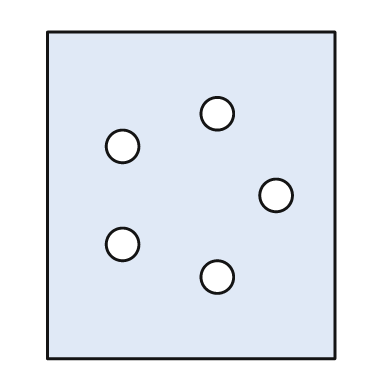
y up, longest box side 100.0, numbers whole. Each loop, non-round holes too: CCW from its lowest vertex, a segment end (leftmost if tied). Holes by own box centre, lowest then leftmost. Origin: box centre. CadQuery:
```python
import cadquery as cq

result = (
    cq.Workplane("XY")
    .moveTo(-44.0, -50.0)
    .lineTo(44.0, -50.0)
    .lineTo(44.0, 50.0)
    .lineTo(-44.0, 50.0)
    .close()
    .moveTo(8.0, -25.0)
    .circle(5.0)
    .moveTo(-21.0, -15.0)
    .circle(5.0)
    .moveTo(26.0, 0.0)
    .circle(5.0)
    .moveTo(-21.0, 15.0)
    .circle(5.0)
    .moveTo(8.0, 25.0)
    .circle(5.0)
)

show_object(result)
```